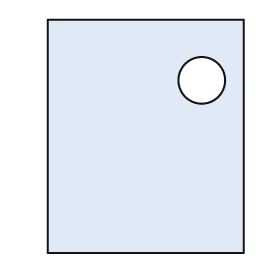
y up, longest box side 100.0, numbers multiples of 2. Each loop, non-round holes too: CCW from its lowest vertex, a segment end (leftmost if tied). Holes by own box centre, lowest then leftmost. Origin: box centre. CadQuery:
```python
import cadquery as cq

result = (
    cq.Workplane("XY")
    .moveTo(-42.0, -50.0)
    .lineTo(42.0, -50.0)
    .lineTo(42.0, 50.0)
    .lineTo(-42.0, 50.0)
    .close()
    .moveTo(24.0, 24.0)
    .circle(10.0)
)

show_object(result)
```